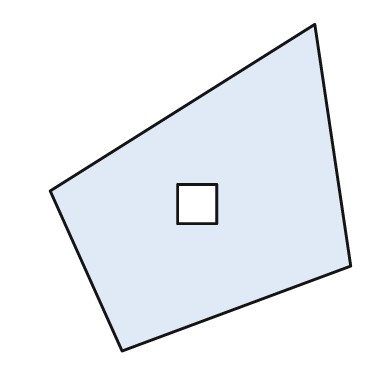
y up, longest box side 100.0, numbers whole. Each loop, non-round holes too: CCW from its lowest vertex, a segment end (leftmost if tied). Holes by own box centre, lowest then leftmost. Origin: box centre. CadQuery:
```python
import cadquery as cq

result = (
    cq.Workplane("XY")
    .moveTo(-24.0, -50.0)
    .lineTo(46.0, -24.0)
    .lineTo(35.0, 50.0)
    .lineTo(-46.0, -1.0)
    .close()
    .moveTo(-7.0, -11.0)
    .lineTo(5.0, -11.0)
    .lineTo(5.0, 1.0)
    .lineTo(-7.0, 1.0)
    .close()
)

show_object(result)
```